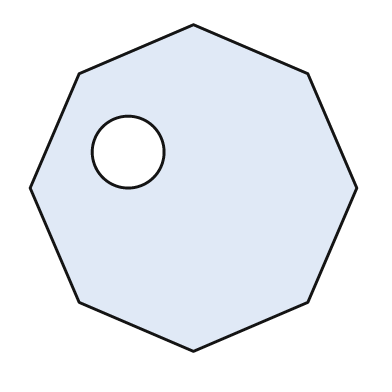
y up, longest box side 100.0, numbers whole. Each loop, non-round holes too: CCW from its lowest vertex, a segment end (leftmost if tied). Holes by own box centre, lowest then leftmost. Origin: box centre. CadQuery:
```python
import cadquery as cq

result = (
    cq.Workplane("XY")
    .moveTo(0.0, -50.0)
    .lineTo(35.0, -35.0)
    .lineTo(50.0, 0.0)
    .lineTo(35.0, 35.0)
    .lineTo(0.0, 50.0)
    .lineTo(-35.0, 35.0)
    .lineTo(-50.0, 0.0)
    .lineTo(-35.0, -35.0)
    .close()
    .moveTo(-20.0, 11.0)
    .circle(11.0)
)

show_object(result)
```